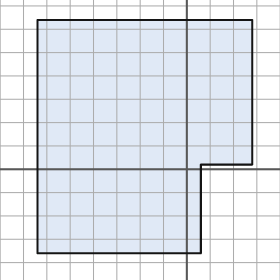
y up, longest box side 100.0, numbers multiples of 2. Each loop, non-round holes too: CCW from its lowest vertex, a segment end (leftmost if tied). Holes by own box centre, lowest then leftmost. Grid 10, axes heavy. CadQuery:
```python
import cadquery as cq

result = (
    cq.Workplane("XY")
    .moveTo(-64.0, -36.0)
    .lineTo(6.0, -36.0)
    .lineTo(6.0, 2.0)
    .lineTo(28.0, 2.0)
    .lineTo(28.0, 64.0)
    .lineTo(-64.0, 64.0)
    .close()
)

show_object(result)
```